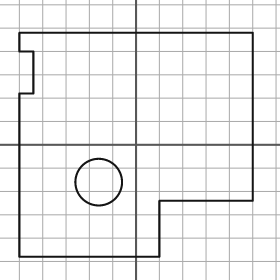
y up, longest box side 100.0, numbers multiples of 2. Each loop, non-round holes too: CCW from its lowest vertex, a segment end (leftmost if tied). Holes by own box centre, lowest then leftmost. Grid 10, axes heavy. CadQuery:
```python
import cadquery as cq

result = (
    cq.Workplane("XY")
    .moveTo(-50.0, -48.0)
    .lineTo(10.0, -48.0)
    .lineTo(10.0, -24.0)
    .lineTo(50.0, -24.0)
    .lineTo(50.0, 48.0)
    .lineTo(-50.0, 48.0)
    .lineTo(-50.0, 40.0)
    .lineTo(-44.0, 40.0)
    .lineTo(-44.0, 22.0)
    .lineTo(-50.0, 22.0)
    .close()
    .moveTo(-16.0, -16.0)
    .circle(10.0)
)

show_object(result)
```